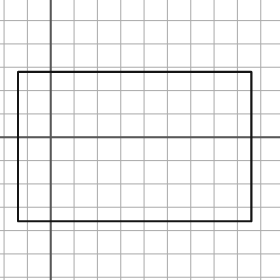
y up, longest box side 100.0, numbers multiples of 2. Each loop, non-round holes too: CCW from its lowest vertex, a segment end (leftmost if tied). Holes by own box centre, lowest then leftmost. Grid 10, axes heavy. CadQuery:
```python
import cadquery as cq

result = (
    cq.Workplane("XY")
    .moveTo(-14.0, -36.0)
    .lineTo(86.0, -36.0)
    .lineTo(86.0, 28.0)
    .lineTo(-14.0, 28.0)
    .close()
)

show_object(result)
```